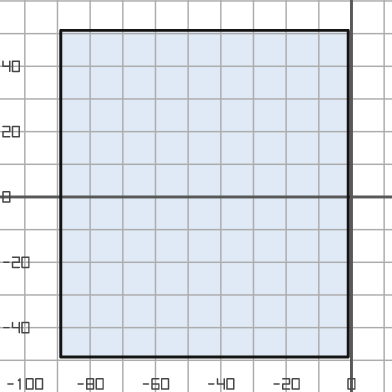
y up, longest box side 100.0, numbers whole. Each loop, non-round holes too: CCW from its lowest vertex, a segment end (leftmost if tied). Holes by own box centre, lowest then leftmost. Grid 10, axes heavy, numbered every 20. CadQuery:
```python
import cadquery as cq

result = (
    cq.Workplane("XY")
    .moveTo(-89.0, -49.0)
    .lineTo(-1.0, -49.0)
    .lineTo(-1.0, 51.0)
    .lineTo(-89.0, 51.0)
    .close()
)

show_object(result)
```